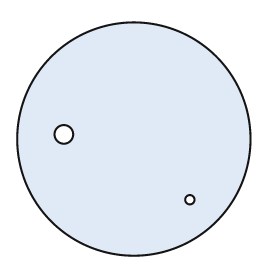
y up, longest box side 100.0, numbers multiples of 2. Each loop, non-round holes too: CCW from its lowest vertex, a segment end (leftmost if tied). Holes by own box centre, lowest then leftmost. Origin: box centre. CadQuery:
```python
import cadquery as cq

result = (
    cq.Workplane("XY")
    .moveTo(0.0, 0.0)
    .circle(50.0)
    .moveTo(24.0, -26.0)
    .circle(2.0)
    .moveTo(-30.0, 2.0)
    .circle(4.0)
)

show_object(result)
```